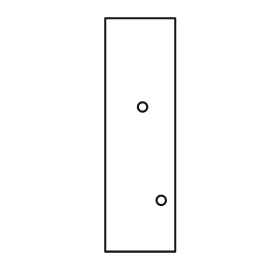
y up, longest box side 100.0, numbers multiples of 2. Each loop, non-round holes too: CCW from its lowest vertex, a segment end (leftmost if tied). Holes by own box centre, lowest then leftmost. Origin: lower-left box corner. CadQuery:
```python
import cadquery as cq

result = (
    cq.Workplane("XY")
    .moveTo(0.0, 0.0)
    .lineTo(30.0, 0.0)
    .lineTo(30.0, 100.0)
    .lineTo(0.0, 100.0)
    .close()
    .moveTo(24.0, 22.0)
    .circle(2.0)
    .moveTo(16.0, 62.0)
    .circle(2.0)
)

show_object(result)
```